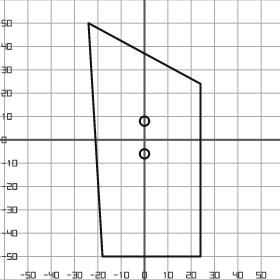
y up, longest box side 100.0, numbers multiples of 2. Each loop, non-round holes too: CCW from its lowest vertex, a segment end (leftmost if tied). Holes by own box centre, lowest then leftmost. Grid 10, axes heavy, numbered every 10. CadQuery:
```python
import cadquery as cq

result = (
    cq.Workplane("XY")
    .moveTo(-18.0, -50.0)
    .lineTo(24.0, -50.0)
    .lineTo(24.0, 24.0)
    .lineTo(-24.0, 50.0)
    .close()
    .moveTo(0.0, -6.0)
    .circle(2.0)
    .moveTo(0.0, 8.0)
    .circle(2.0)
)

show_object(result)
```